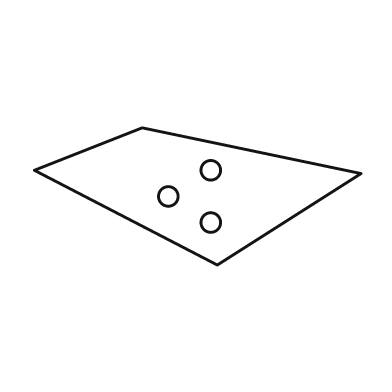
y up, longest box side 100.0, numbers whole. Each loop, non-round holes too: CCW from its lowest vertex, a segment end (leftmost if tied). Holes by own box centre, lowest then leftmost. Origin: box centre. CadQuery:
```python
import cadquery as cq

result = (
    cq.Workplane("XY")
    .moveTo(6.0, -21.0)
    .lineTo(50.0, 7.0)
    .lineTo(-17.0, 21.0)
    .lineTo(-50.0, 8.0)
    .close()
    .moveTo(4.0, -8.0)
    .circle(3.0)
    .moveTo(-9.0, 0.0)
    .circle(3.0)
    .moveTo(4.0, 8.0)
    .circle(3.0)
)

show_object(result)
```